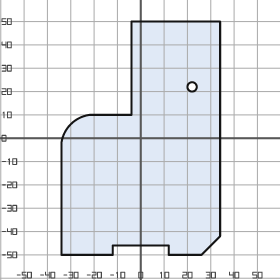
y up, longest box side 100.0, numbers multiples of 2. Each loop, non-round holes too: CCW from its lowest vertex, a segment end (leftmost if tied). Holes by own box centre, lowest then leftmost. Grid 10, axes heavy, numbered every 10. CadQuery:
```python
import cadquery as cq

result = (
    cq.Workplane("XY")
    .moveTo(-34.0, -50.0)
    .lineTo(-12.0, -50.0)
    .lineTo(-12.0, -46.0)
    .lineTo(12.0, -46.0)
    .lineTo(12.0, -50.0)
    .lineTo(26.0, -50.0)
    .lineTo(34.0, -42.0)
    .lineTo(34.0, 50.0)
    .lineTo(-4.0, 50.0)
    .lineTo(-4.0, 10.0)
    .lineTo(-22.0, 10.0)
    .threePointArc((-30.0, 6.0), (-34.0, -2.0))
    .close()
    .moveTo(22.0, 22.0)
    .circle(2.0)
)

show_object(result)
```